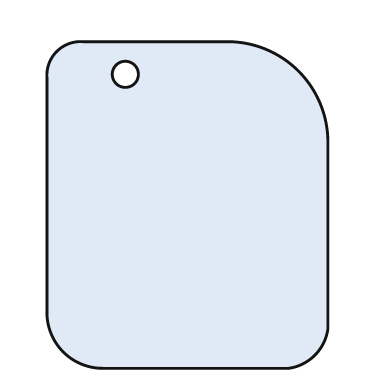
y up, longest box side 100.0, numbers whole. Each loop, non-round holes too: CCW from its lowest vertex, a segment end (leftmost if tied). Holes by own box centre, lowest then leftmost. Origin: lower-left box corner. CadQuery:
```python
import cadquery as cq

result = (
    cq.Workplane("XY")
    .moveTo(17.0, 0.0)
    .lineTo(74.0, 0.0)
    .threePointArc((82.0, 4.0), (86.0, 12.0))
    .lineTo(86.0, 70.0)
    .threePointArc((77.0, 91.0), (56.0, 100.0))
    .lineTo(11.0, 100.0)
    .threePointArc((3.0, 97.0), (0.0, 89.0))
    .lineTo(0.0, 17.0)
    .threePointArc((5.0, 5.0), (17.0, 0.0))
    .close()
    .moveTo(24.0, 90.0)
    .circle(4.0)
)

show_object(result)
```